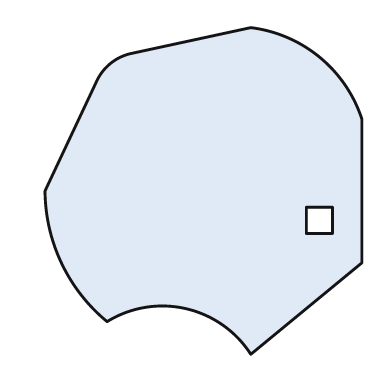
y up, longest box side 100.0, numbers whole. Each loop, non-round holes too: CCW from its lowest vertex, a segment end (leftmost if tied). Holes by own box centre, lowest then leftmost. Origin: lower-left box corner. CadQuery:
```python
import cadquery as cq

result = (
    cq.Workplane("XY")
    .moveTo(63.0, 0.0)
    .lineTo(97.0, 28.0)
    .lineTo(97.0, 72.0)
    .threePointArc((84.0, 91.0), (63.0, 100.0))
    .lineTo(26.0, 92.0)
    .threePointArc((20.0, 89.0), (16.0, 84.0))
    .lineTo(0.0, 50.0)
    .threePointArc((5.0, 28.0), (19.0, 10.0))
    .threePointArc((43.0, 14.0), (63.0, 0.0))
    .close()
    .moveTo(80.0, 37.0)
    .lineTo(88.0, 37.0)
    .lineTo(88.0, 45.0)
    .lineTo(80.0, 45.0)
    .close()
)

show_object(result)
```